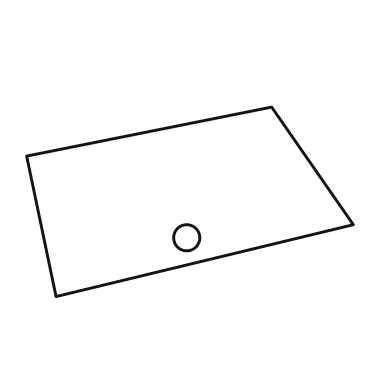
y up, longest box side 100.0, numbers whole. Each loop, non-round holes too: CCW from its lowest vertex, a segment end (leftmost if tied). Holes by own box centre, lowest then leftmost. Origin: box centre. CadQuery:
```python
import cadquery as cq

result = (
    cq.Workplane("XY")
    .moveTo(-41.0, -29.0)
    .lineTo(50.0, -7.0)
    .lineTo(25.0, 29.0)
    .lineTo(-50.0, 14.0)
    .close()
    .moveTo(-1.0, -11.0)
    .circle(4.0)
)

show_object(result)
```